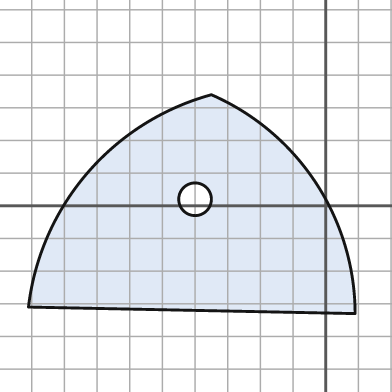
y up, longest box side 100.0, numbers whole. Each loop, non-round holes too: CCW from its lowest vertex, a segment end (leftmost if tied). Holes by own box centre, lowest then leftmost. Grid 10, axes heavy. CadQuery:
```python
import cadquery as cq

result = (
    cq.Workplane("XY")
    .moveTo(9.0, -33.0)
    .threePointArc((-3.0, 7.0), (-35.0, 34.0))
    .threePointArc((-73.0, 10.0), (-91.0, -31.0))
    .close()
    .moveTo(-40.0, 2.0)
    .circle(5.0)
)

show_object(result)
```